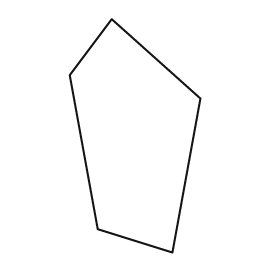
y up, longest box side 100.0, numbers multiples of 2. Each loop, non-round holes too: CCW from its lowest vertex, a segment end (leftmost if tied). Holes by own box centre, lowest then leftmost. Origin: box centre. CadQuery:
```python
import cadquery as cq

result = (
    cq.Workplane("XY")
    .moveTo(16.0, -50.0)
    .lineTo(28.0, 16.0)
    .lineTo(-10.0, 50.0)
    .lineTo(-28.0, 26.0)
    .lineTo(-16.0, -40.0)
    .close()
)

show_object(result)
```